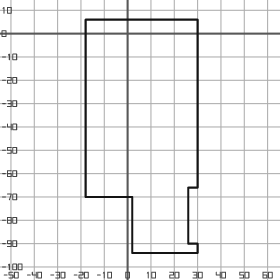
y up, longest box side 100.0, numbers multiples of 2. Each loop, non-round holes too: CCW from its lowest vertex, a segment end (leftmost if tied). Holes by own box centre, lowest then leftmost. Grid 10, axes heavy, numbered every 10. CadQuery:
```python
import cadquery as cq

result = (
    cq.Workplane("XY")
    .moveTo(2.0, -94.0)
    .lineTo(30.0, -94.0)
    .lineTo(30.0, -90.0)
    .lineTo(26.0, -90.0)
    .lineTo(26.0, -66.0)
    .lineTo(30.0, -66.0)
    .lineTo(30.0, 6.0)
    .lineTo(-18.0, 6.0)
    .lineTo(-18.0, -70.0)
    .lineTo(2.0, -70.0)
    .close()
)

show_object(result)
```